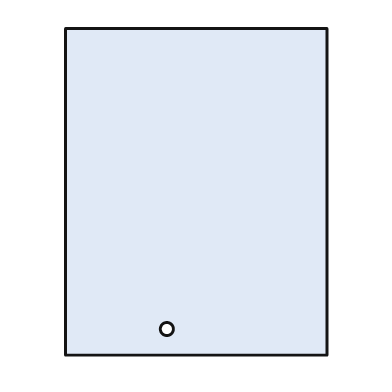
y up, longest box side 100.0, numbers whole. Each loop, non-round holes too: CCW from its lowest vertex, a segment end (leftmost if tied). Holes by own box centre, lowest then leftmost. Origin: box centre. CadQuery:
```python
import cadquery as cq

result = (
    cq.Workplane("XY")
    .moveTo(-40.0, -50.0)
    .lineTo(40.0, -50.0)
    .lineTo(40.0, 50.0)
    .lineTo(-40.0, 50.0)
    .close()
    .moveTo(-9.0, -42.0)
    .circle(2.0)
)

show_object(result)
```